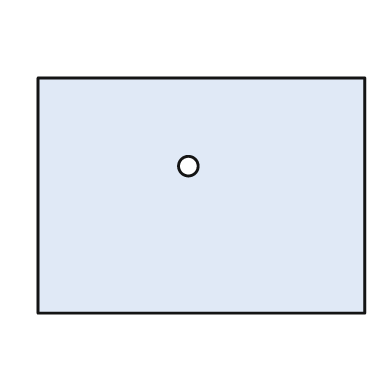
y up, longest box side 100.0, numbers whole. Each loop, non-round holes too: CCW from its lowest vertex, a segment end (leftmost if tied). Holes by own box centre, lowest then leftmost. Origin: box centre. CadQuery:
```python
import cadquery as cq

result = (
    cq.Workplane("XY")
    .moveTo(-50.0, -36.0)
    .lineTo(50.0, -36.0)
    .lineTo(50.0, 36.0)
    .lineTo(-50.0, 36.0)
    .close()
    .moveTo(-4.0, 9.0)
    .circle(3.0)
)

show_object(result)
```